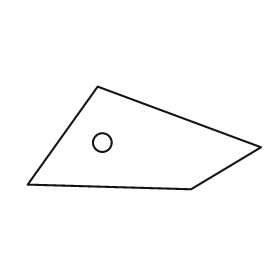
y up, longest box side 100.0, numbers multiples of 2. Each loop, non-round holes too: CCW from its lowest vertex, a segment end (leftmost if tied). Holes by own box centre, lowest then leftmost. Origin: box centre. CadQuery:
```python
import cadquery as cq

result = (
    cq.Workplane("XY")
    .moveTo(20.0, -22.0)
    .lineTo(50.0, -4.0)
    .lineTo(-20.0, 22.0)
    .lineTo(-50.0, -20.0)
    .close()
    .moveTo(-18.0, -2.0)
    .circle(4.0)
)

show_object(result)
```